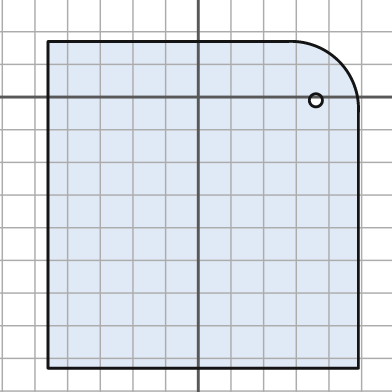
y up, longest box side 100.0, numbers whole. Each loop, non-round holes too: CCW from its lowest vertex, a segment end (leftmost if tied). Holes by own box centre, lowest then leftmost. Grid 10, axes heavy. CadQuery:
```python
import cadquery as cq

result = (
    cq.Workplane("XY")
    .moveTo(-46.0, -83.0)
    .lineTo(49.0, -83.0)
    .lineTo(49.0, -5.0)
    .threePointArc((43.0, 11.0), (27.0, 17.0))
    .lineTo(-46.0, 17.0)
    .close()
    .moveTo(36.0, -1.0)
    .circle(2.0)
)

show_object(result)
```